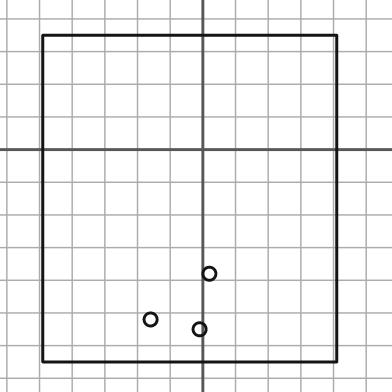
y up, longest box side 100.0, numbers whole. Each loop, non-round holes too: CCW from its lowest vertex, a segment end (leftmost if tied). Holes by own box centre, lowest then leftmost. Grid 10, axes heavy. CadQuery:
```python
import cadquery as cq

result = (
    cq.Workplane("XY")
    .moveTo(-49.0, -65.0)
    .lineTo(41.0, -65.0)
    .lineTo(41.0, 35.0)
    .lineTo(-49.0, 35.0)
    .close()
    .moveTo(-1.0, -55.0)
    .circle(2.0)
    .moveTo(-16.0, -52.0)
    .circle(2.0)
    .moveTo(2.0, -38.0)
    .circle(2.0)
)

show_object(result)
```